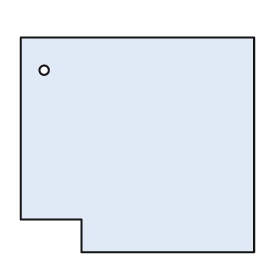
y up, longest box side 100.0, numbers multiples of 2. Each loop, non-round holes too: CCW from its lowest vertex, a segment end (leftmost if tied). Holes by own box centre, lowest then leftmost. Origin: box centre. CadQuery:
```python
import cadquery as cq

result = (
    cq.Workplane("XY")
    .moveTo(-24.0, -46.0)
    .lineTo(50.0, -46.0)
    .lineTo(50.0, 46.0)
    .lineTo(-50.0, 46.0)
    .lineTo(-50.0, -32.0)
    .lineTo(-24.0, -32.0)
    .close()
    .moveTo(-40.0, 32.0)
    .circle(2.0)
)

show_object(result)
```